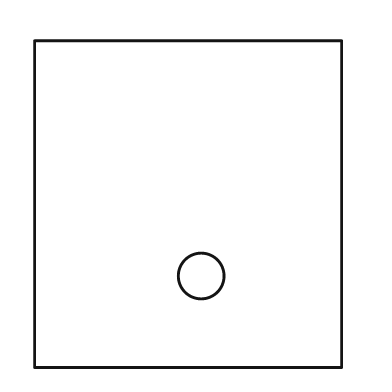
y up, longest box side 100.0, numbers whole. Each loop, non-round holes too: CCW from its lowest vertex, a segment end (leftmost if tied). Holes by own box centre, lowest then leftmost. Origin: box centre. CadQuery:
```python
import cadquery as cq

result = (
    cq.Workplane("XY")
    .moveTo(-47.0, -50.0)
    .lineTo(47.0, -50.0)
    .lineTo(47.0, 50.0)
    .lineTo(-47.0, 50.0)
    .close()
    .moveTo(4.0, -22.0)
    .circle(7.0)
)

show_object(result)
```